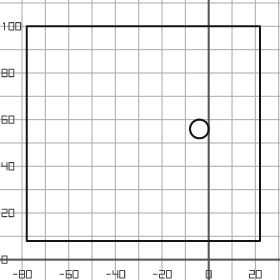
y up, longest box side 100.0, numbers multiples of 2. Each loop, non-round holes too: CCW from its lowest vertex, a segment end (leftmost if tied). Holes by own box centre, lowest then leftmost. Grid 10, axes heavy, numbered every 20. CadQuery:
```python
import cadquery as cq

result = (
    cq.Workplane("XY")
    .moveTo(-78.0, 8.0)
    .lineTo(22.0, 8.0)
    .lineTo(22.0, 100.0)
    .lineTo(-78.0, 100.0)
    .close()
    .moveTo(-4.0, 56.0)
    .circle(4.0)
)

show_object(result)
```